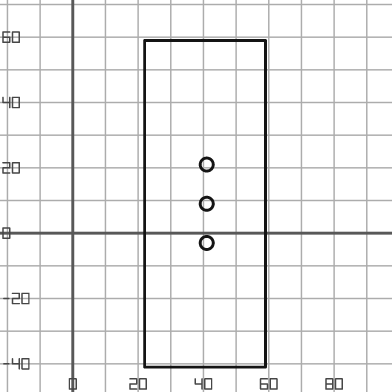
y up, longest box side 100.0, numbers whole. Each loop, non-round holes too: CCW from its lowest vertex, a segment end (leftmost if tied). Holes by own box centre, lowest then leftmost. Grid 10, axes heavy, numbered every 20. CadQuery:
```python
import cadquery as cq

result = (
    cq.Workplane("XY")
    .moveTo(22.0, -41.0)
    .lineTo(59.0, -41.0)
    .lineTo(59.0, 59.0)
    .lineTo(22.0, 59.0)
    .close()
    .moveTo(41.0, -3.0)
    .circle(2.0)
    .moveTo(41.0, 9.0)
    .circle(2.0)
    .moveTo(41.0, 21.0)
    .circle(2.0)
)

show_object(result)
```